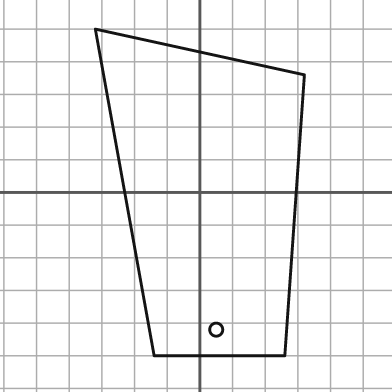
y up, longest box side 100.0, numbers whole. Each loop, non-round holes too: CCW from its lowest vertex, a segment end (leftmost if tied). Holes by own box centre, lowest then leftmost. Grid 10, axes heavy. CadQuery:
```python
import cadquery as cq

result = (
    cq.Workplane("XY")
    .moveTo(-14.0, -50.0)
    .lineTo(26.0, -50.0)
    .lineTo(32.0, 36.0)
    .lineTo(-32.0, 50.0)
    .close()
    .moveTo(5.0, -42.0)
    .circle(2.0)
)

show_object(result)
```